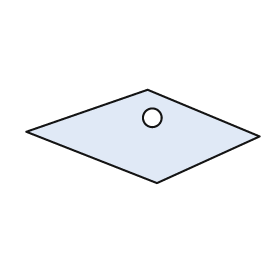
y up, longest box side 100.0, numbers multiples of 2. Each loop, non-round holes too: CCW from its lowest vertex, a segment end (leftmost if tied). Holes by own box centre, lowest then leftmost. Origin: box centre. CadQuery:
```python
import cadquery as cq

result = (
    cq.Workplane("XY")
    .moveTo(6.0, -20.0)
    .lineTo(50.0, 0.0)
    .lineTo(2.0, 20.0)
    .lineTo(-50.0, 2.0)
    .close()
    .moveTo(4.0, 8.0)
    .circle(4.0)
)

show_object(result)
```